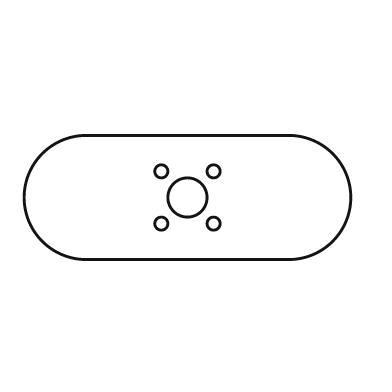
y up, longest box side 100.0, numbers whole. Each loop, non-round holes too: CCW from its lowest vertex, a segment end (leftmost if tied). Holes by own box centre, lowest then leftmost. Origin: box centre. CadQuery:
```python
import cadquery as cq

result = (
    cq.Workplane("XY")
    .moveTo(-31.0, -19.0)
    .lineTo(31.0, -19.0)
    .threePointArc((50.0, 0.0), (31.0, 19.0))
    .lineTo(-31.0, 19.0)
    .threePointArc((-50.0, 0.0), (-31.0, -19.0))
    .close()
    .moveTo(-8.0, -8.0)
    .circle(2.0)
    .moveTo(8.0, -8.0)
    .circle(2.0)
    .moveTo(0.0, 0.0)
    .circle(6.0)
    .moveTo(-8.0, 8.0)
    .circle(2.0)
    .moveTo(8.0, 8.0)
    .circle(2.0)
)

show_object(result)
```